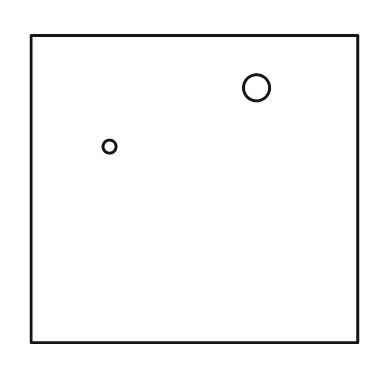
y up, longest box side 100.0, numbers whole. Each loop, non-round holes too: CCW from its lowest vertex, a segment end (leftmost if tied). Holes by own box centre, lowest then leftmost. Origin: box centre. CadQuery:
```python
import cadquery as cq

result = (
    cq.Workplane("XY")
    .moveTo(-50.0, -47.0)
    .lineTo(50.0, -47.0)
    .lineTo(50.0, 47.0)
    .lineTo(-50.0, 47.0)
    .close()
    .moveTo(-26.0, 13.0)
    .circle(2.0)
    .moveTo(19.0, 31.0)
    .circle(4.0)
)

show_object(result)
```